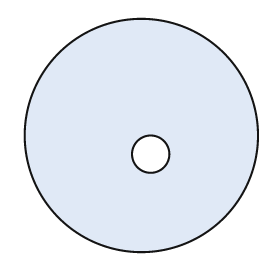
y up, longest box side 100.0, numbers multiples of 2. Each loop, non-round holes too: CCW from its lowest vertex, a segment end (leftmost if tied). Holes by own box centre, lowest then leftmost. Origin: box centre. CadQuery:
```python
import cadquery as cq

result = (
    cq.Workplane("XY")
    .moveTo(0.0, 0.0)
    .circle(50.0)
    .moveTo(4.0, -8.0)
    .circle(8.0)
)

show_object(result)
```